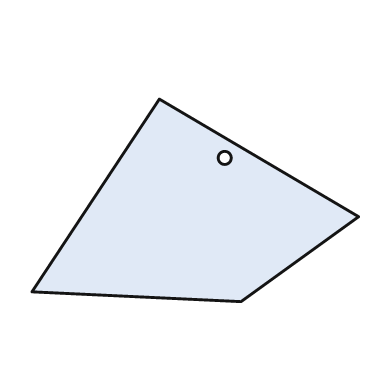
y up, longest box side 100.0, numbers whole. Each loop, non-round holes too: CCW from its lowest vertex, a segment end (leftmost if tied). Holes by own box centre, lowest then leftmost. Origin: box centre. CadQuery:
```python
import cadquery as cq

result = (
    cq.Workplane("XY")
    .moveTo(14.0, -31.0)
    .lineTo(50.0, -5.0)
    .lineTo(-11.0, 31.0)
    .lineTo(-50.0, -28.0)
    .close()
    .moveTo(9.0, 13.0)
    .circle(2.0)
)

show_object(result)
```